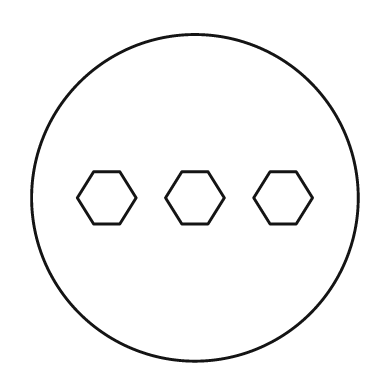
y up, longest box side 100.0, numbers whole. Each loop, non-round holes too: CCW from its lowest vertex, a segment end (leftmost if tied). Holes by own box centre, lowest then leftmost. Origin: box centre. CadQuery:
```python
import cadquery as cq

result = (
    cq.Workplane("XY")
    .moveTo(0.0, 0.0)
    .circle(50.0)
    .moveTo(-31.0, -8.0)
    .lineTo(-23.0, -8.0)
    .lineTo(-18.0, 0.0)
    .lineTo(-23.0, 8.0)
    .lineTo(-31.0, 8.0)
    .lineTo(-36.0, 0.0)
    .close()
    .moveTo(-4.0, -8.0)
    .lineTo(4.0, -8.0)
    .lineTo(9.0, 0.0)
    .lineTo(4.0, 8.0)
    .lineTo(-4.0, 8.0)
    .lineTo(-9.0, 0.0)
    .close()
    .moveTo(23.0, -8.0)
    .lineTo(31.0, -8.0)
    .lineTo(36.0, 0.0)
    .lineTo(31.0, 8.0)
    .lineTo(23.0, 8.0)
    .lineTo(18.0, 0.0)
    .close()
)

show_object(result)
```